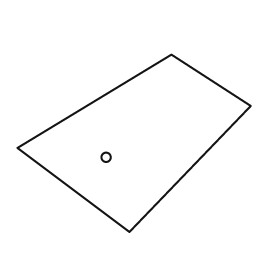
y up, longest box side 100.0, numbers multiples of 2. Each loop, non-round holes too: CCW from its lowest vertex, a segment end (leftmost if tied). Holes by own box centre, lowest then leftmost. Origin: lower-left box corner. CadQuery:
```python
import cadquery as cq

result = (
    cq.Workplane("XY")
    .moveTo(48.0, 0.0)
    .lineTo(100.0, 54.0)
    .lineTo(66.0, 76.0)
    .lineTo(0.0, 36.0)
    .close()
    .moveTo(38.0, 32.0)
    .circle(2.0)
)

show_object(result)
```